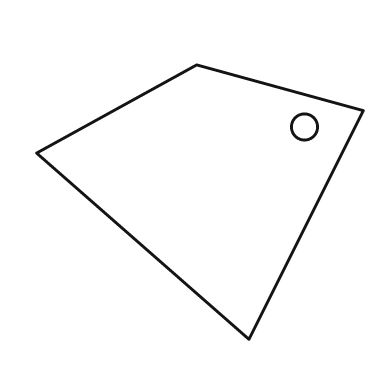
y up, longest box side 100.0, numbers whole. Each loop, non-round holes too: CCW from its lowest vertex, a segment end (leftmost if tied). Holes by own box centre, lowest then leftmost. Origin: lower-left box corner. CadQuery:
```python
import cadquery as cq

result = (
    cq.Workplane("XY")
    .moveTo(65.0, 0.0)
    .lineTo(100.0, 70.0)
    .lineTo(49.0, 84.0)
    .lineTo(0.0, 57.0)
    .close()
    .moveTo(82.0, 65.0)
    .circle(4.0)
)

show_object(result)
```